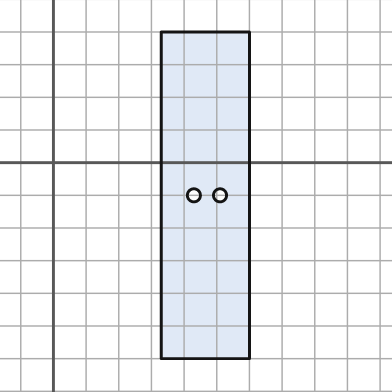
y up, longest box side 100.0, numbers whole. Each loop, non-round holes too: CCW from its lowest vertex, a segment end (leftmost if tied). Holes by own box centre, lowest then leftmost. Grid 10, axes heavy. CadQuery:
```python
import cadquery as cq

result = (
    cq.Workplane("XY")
    .moveTo(33.0, -60.0)
    .lineTo(60.0, -60.0)
    .lineTo(60.0, 40.0)
    .lineTo(33.0, 40.0)
    .close()
    .moveTo(43.0, -10.0)
    .circle(2.0)
    .moveTo(51.0, -10.0)
    .circle(2.0)
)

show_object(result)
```